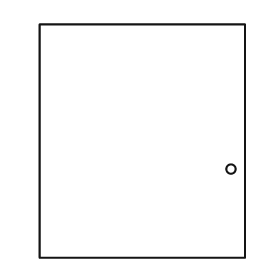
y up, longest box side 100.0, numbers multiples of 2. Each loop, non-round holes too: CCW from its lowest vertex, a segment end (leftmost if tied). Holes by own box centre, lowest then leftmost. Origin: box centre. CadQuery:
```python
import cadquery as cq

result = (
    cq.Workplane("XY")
    .moveTo(-44.0, -50.0)
    .lineTo(44.0, -50.0)
    .lineTo(44.0, 50.0)
    .lineTo(-44.0, 50.0)
    .close()
    .moveTo(38.0, -12.0)
    .circle(2.0)
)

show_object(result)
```